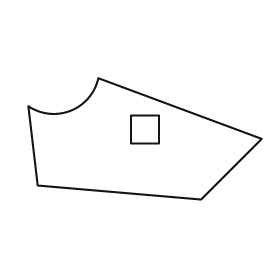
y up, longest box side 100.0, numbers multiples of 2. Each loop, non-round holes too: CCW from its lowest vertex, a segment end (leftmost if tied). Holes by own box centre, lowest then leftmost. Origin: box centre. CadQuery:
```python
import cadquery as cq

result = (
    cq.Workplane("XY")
    .moveTo(24.0, -26.0)
    .lineTo(50.0, 0.0)
    .lineTo(-20.0, 26.0)
    .threePointArc((-32.0, 12.0), (-50.0, 14.0))
    .lineTo(-46.0, -20.0)
    .close()
    .moveTo(-6.0, -2.0)
    .lineTo(6.0, -2.0)
    .lineTo(6.0, 10.0)
    .lineTo(-6.0, 10.0)
    .close()
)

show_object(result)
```